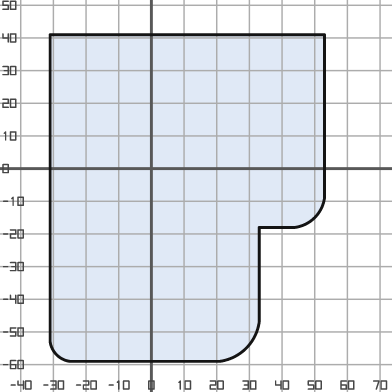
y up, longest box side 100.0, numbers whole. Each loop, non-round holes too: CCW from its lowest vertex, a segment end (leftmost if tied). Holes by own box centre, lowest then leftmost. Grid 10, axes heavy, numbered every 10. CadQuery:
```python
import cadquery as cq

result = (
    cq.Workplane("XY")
    .moveTo(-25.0, -59.0)
    .lineTo(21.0, -59.0)
    .threePointArc((29.0, -55.0), (33.0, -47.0))
    .lineTo(33.0, -18.0)
    .lineTo(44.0, -18.0)
    .threePointArc((50.0, -15.0), (53.0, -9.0))
    .lineTo(53.0, 41.0)
    .lineTo(-31.0, 41.0)
    .lineTo(-31.0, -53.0)
    .threePointArc((-29.0, -57.0), (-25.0, -59.0))
    .close()
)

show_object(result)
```